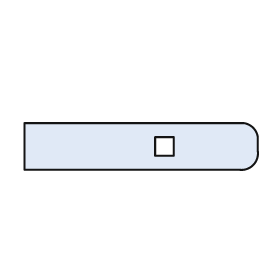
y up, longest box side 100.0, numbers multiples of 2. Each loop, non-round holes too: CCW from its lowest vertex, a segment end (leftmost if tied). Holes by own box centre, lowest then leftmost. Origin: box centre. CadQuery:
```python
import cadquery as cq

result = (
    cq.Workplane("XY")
    .moveTo(-50.0, -10.0)
    .lineTo(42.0, -10.0)
    .threePointArc((48.0, -8.0), (50.0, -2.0))
    .lineTo(50.0, 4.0)
    .threePointArc((48.0, 8.0), (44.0, 10.0))
    .lineTo(-50.0, 10.0)
    .close()
    .moveTo(6.0, -4.0)
    .lineTo(14.0, -4.0)
    .lineTo(14.0, 4.0)
    .lineTo(6.0, 4.0)
    .close()
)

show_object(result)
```